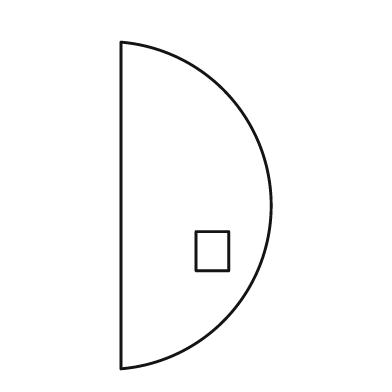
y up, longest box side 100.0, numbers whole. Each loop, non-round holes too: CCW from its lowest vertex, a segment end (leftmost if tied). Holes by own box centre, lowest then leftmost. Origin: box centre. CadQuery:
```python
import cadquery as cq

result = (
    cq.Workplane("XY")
    .moveTo(-23.0, -50.0)
    .threePointArc((23.0, 0.0), (-23.0, 50.0))
    .close()
    .moveTo(0.0, -20.0)
    .lineTo(10.0, -20.0)
    .lineTo(10.0, -8.0)
    .lineTo(0.0, -8.0)
    .close()
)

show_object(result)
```